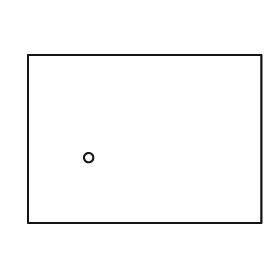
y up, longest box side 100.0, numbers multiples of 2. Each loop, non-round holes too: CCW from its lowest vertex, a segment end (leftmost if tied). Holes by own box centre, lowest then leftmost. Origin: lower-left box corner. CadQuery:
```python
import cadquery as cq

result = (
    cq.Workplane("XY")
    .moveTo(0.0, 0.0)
    .lineTo(100.0, 0.0)
    .lineTo(100.0, 72.0)
    .lineTo(0.0, 72.0)
    .close()
    .moveTo(26.0, 28.0)
    .circle(2.0)
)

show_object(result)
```